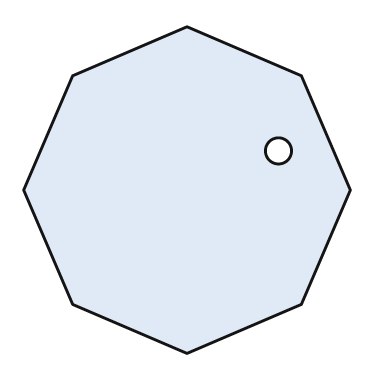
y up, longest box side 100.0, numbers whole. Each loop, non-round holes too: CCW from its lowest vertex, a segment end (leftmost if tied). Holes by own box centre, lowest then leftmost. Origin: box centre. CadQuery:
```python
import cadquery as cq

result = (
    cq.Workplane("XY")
    .moveTo(0.0, -50.0)
    .lineTo(35.0, -35.0)
    .lineTo(50.0, 0.0)
    .lineTo(35.0, 35.0)
    .lineTo(0.0, 50.0)
    .lineTo(-35.0, 35.0)
    .lineTo(-50.0, 0.0)
    .lineTo(-35.0, -35.0)
    .close()
    .moveTo(28.0, 12.0)
    .circle(4.0)
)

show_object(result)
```